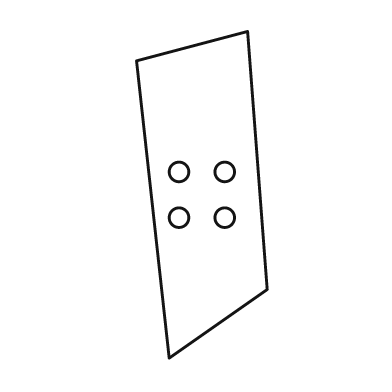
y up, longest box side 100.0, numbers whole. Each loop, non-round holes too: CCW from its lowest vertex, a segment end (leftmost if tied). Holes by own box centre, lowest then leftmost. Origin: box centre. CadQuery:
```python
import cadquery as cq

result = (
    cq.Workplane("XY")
    .moveTo(-10.0, -50.0)
    .lineTo(20.0, -29.0)
    .lineTo(14.0, 50.0)
    .lineTo(-20.0, 41.0)
    .close()
    .moveTo(-7.0, -7.0)
    .circle(3.0)
    .moveTo(7.0, -7.0)
    .circle(3.0)
    .moveTo(-7.0, 7.0)
    .circle(3.0)
    .moveTo(7.0, 7.0)
    .circle(3.0)
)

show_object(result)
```